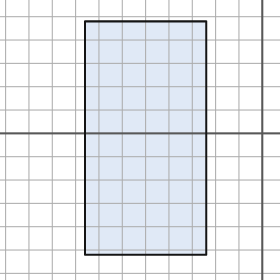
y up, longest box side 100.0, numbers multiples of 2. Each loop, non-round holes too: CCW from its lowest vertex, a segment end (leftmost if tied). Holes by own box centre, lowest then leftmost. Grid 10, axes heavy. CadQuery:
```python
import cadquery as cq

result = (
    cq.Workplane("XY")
    .moveTo(-76.0, -52.0)
    .lineTo(-24.0, -52.0)
    .lineTo(-24.0, 48.0)
    .lineTo(-76.0, 48.0)
    .close()
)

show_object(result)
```